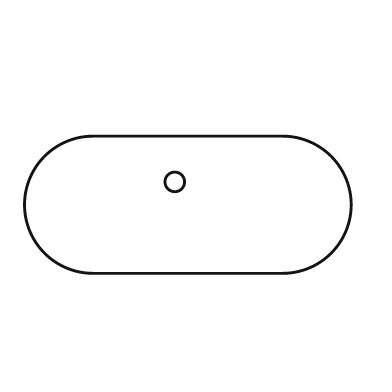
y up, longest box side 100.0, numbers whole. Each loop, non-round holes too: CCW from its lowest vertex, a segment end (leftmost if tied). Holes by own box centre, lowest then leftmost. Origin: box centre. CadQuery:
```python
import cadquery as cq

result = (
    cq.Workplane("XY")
    .moveTo(-29.0, -21.0)
    .lineTo(29.0, -21.0)
    .threePointArc((50.0, 0.0), (29.0, 21.0))
    .lineTo(-29.0, 21.0)
    .threePointArc((-50.0, 0.0), (-29.0, -21.0))
    .close()
    .moveTo(-4.0, 7.0)
    .circle(3.0)
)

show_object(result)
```